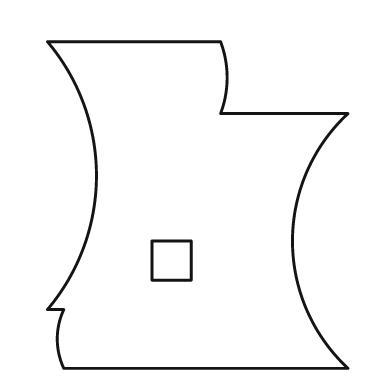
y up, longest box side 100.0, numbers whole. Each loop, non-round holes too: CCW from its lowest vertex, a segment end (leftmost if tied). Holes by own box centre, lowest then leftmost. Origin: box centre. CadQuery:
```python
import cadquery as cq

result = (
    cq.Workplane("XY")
    .moveTo(-41.0, -50.0)
    .lineTo(46.0, -50.0)
    .threePointArc((29.0, -11.0), (46.0, 28.0))
    .lineTo(7.0, 28.0)
    .threePointArc((9.0, 39.0), (7.0, 50.0))
    .lineTo(-46.0, 50.0)
    .threePointArc((-31.0, 9.0), (-46.0, -32.0))
    .lineTo(-41.0, -32.0)
    .threePointArc((-43.0, -41.0), (-41.0, -50.0))
    .close()
    .moveTo(-14.0, -23.0)
    .lineTo(-2.0, -23.0)
    .lineTo(-2.0, -11.0)
    .lineTo(-14.0, -11.0)
    .close()
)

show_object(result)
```